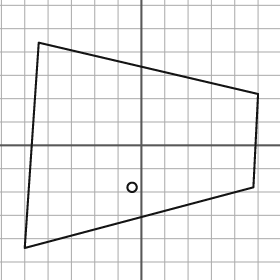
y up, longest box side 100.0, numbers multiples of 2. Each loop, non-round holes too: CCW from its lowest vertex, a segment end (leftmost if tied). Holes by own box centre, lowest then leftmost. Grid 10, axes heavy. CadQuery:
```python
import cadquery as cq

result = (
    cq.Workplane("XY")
    .moveTo(-50.0, -44.0)
    .lineTo(48.0, -18.0)
    .lineTo(50.0, 22.0)
    .lineTo(-44.0, 44.0)
    .close()
    .moveTo(-4.0, -18.0)
    .circle(2.0)
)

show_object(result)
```